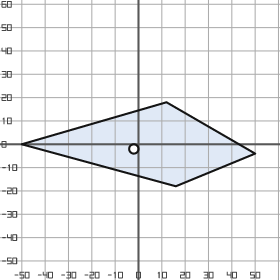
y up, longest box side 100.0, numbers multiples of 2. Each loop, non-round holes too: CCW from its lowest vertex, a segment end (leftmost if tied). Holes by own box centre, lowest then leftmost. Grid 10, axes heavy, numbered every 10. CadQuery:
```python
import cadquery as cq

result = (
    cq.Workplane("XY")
    .moveTo(16.0, -18.0)
    .lineTo(50.0, -4.0)
    .lineTo(12.0, 18.0)
    .lineTo(-50.0, 0.0)
    .close()
    .moveTo(-2.0, -2.0)
    .circle(2.0)
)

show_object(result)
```